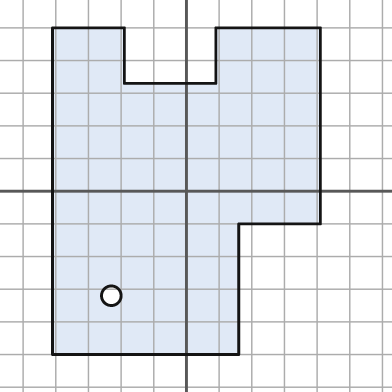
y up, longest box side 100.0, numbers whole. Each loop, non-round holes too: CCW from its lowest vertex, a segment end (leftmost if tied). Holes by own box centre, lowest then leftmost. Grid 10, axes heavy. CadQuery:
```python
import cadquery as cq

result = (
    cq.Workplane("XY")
    .moveTo(-41.0, -50.0)
    .lineTo(16.0, -50.0)
    .lineTo(16.0, -10.0)
    .lineTo(41.0, -10.0)
    .lineTo(41.0, 50.0)
    .lineTo(9.0, 50.0)
    .lineTo(9.0, 33.0)
    .lineTo(-19.0, 33.0)
    .lineTo(-19.0, 50.0)
    .lineTo(-41.0, 50.0)
    .close()
    .moveTo(-23.0, -32.0)
    .circle(3.0)
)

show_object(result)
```